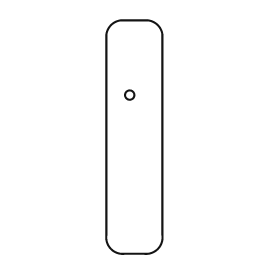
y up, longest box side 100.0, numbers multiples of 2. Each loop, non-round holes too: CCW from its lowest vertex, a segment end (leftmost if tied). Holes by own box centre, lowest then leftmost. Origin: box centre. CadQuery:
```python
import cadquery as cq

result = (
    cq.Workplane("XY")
    .moveTo(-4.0, -50.0)
    .lineTo(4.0, -50.0)
    .threePointArc((10.0, -48.0), (12.0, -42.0))
    .lineTo(12.0, 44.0)
    .threePointArc((10.0, 48.0), (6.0, 50.0))
    .lineTo(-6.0, 50.0)
    .threePointArc((-10.0, 48.0), (-12.0, 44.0))
    .lineTo(-12.0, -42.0)
    .threePointArc((-10.0, -48.0), (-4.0, -50.0))
    .close()
    .moveTo(-2.0, 18.0)
    .circle(2.0)
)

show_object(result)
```